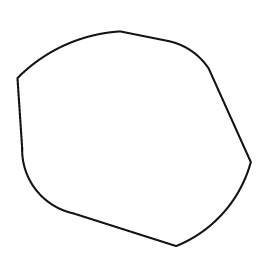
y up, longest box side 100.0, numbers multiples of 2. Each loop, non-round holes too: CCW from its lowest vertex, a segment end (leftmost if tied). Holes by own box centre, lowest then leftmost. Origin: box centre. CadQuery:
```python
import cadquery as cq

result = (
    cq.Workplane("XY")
    .moveTo(18.0, -46.0)
    .threePointArc((38.0, -32.0), (50.0, -10.0))
    .lineTo(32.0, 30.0)
    .threePointArc((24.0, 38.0), (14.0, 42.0))
    .lineTo(-6.0, 46.0)
    .threePointArc((-30.0, 40.0), (-50.0, 26.0))
    .lineTo(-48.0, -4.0)
    .threePointArc((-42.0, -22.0), (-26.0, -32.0))
    .close()
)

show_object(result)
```